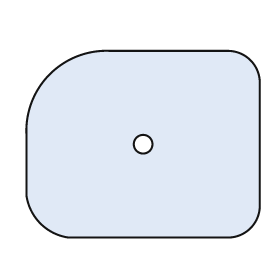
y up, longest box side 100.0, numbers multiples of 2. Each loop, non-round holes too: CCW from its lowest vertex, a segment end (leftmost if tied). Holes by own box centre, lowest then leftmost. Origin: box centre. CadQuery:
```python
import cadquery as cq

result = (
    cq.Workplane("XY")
    .moveTo(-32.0, -40.0)
    .lineTo(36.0, -40.0)
    .threePointArc((46.0, -36.0), (50.0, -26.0))
    .lineTo(50.0, 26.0)
    .threePointArc((46.0, 36.0), (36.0, 40.0))
    .lineTo(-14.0, 40.0)
    .threePointArc((-40.0, 30.0), (-50.0, 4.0))
    .lineTo(-50.0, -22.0)
    .threePointArc((-44.0, -34.0), (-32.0, -40.0))
    .close()
    .moveTo(0.0, 0.0)
    .circle(4.0)
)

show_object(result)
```